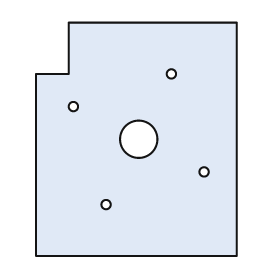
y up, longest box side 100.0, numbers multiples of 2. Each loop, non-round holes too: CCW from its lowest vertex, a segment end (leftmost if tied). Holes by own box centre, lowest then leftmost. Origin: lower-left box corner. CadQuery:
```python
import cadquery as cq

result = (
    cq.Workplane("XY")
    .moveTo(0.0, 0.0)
    .lineTo(86.0, 0.0)
    .lineTo(86.0, 100.0)
    .lineTo(14.0, 100.0)
    .lineTo(14.0, 78.0)
    .lineTo(0.0, 78.0)
    .close()
    .moveTo(30.0, 22.0)
    .circle(2.0)
    .moveTo(72.0, 36.0)
    .circle(2.0)
    .moveTo(44.0, 50.0)
    .circle(8.0)
    .moveTo(16.0, 64.0)
    .circle(2.0)
    .moveTo(58.0, 78.0)
    .circle(2.0)
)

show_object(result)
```